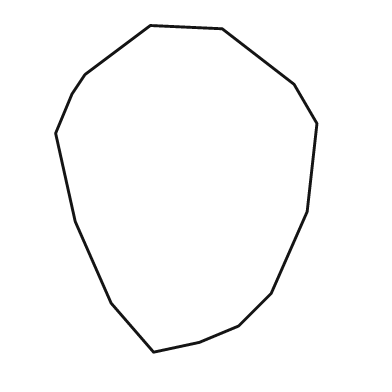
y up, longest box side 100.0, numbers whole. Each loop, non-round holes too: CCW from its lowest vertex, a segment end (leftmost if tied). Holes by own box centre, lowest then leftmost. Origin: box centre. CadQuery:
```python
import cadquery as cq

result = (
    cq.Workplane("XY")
    .moveTo(-10.0, -50.0)
    .lineTo(4.0, -47.0)
    .lineTo(16.0, -42.0)
    .lineTo(26.0, -32.0)
    .lineTo(37.0, -7.0)
    .lineTo(40.0, 20.0)
    .lineTo(33.0, 32.0)
    .lineTo(11.0, 49.0)
    .lineTo(-11.0, 50.0)
    .lineTo(-31.0, 35.0)
    .lineTo(-35.0, 29.0)
    .lineTo(-40.0, 17.0)
    .lineTo(-34.0, -10.0)
    .lineTo(-23.0, -35.0)
    .close()
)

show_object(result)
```